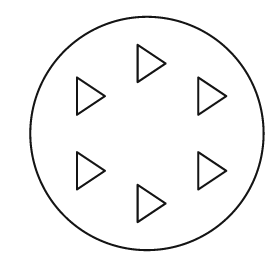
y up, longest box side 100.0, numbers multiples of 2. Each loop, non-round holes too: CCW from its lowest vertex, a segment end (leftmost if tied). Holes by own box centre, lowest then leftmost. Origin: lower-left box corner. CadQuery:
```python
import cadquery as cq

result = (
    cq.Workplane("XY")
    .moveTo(50.0, 50.0)
    .circle(50.0)
    .moveTo(46.0, 12.0)
    .lineTo(58.0, 20.0)
    .lineTo(46.0, 28.0)
    .close()
    .moveTo(20.0, 26.0)
    .lineTo(32.0, 34.0)
    .lineTo(20.0, 42.0)
    .close()
    .moveTo(72.0, 26.0)
    .lineTo(84.0, 34.0)
    .lineTo(72.0, 42.0)
    .close()
    .moveTo(20.0, 58.0)
    .lineTo(32.0, 66.0)
    .lineTo(20.0, 74.0)
    .close()
    .moveTo(72.0, 58.0)
    .lineTo(84.0, 66.0)
    .lineTo(72.0, 74.0)
    .close()
    .moveTo(46.0, 72.0)
    .lineTo(58.0, 80.0)
    .lineTo(46.0, 88.0)
    .close()
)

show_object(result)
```